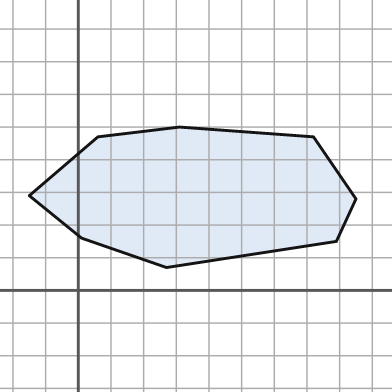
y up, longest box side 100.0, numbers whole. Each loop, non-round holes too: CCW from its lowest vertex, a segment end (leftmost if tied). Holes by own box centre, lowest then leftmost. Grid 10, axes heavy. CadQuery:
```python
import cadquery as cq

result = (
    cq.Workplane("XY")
    .moveTo(27.0, 7.0)
    .lineTo(79.0, 15.0)
    .lineTo(85.0, 28.0)
    .lineTo(72.0, 47.0)
    .lineTo(31.0, 50.0)
    .lineTo(6.0, 47.0)
    .lineTo(-15.0, 29.0)
    .lineTo(1.0, 16.0)
    .close()
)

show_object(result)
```